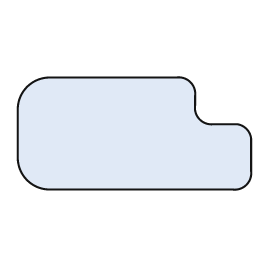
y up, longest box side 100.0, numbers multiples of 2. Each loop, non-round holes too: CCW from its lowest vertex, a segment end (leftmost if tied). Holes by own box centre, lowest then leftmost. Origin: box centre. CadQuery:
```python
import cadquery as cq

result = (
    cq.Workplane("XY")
    .moveTo(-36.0, -24.0)
    .lineTo(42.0, -24.0)
    .threePointArc((48.0, -22.0), (50.0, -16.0))
    .lineTo(50.0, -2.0)
    .threePointArc((48.0, 2.0), (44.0, 4.0))
    .lineTo(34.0, 4.0)
    .threePointArc((28.0, 6.0), (26.0, 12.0))
    .lineTo(26.0, 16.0)
    .threePointArc((24.0, 22.0), (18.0, 24.0))
    .lineTo(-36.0, 24.0)
    .threePointArc((-46.0, 20.0), (-50.0, 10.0))
    .lineTo(-50.0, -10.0)
    .threePointArc((-46.0, -20.0), (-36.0, -24.0))
    .close()
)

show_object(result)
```